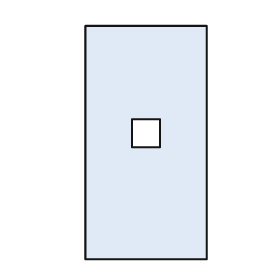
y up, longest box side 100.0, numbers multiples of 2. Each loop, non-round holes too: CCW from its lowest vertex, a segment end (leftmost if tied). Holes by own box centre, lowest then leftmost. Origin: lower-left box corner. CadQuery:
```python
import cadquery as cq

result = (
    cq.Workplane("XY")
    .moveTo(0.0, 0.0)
    .lineTo(52.0, 0.0)
    .lineTo(52.0, 100.0)
    .lineTo(0.0, 100.0)
    .close()
    .moveTo(20.0, 48.0)
    .lineTo(32.0, 48.0)
    .lineTo(32.0, 60.0)
    .lineTo(20.0, 60.0)
    .close()
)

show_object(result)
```